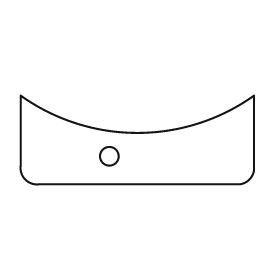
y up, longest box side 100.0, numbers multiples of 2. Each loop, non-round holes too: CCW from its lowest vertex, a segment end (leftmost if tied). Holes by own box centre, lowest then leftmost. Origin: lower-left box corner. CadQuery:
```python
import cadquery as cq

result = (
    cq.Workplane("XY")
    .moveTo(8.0, 0.0)
    .lineTo(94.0, 0.0)
    .threePointArc((98.0, 2.0), (100.0, 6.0))
    .lineTo(100.0, 38.0)
    .threePointArc((50.0, 22.0), (0.0, 38.0))
    .lineTo(0.0, 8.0)
    .threePointArc((2.0, 2.0), (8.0, 0.0))
    .close()
    .moveTo(38.0, 12.0)
    .circle(4.0)
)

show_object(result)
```